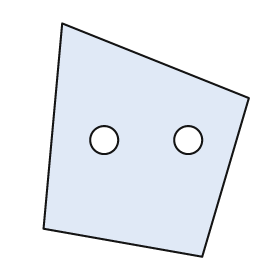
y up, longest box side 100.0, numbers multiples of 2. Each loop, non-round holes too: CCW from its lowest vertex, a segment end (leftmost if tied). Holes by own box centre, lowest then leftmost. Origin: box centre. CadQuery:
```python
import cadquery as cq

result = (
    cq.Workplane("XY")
    .moveTo(24.0, -50.0)
    .lineTo(44.0, 18.0)
    .lineTo(-36.0, 50.0)
    .lineTo(-44.0, -38.0)
    .close()
    .moveTo(-18.0, 0.0)
    .circle(6.0)
    .moveTo(18.0, 0.0)
    .circle(6.0)
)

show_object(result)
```